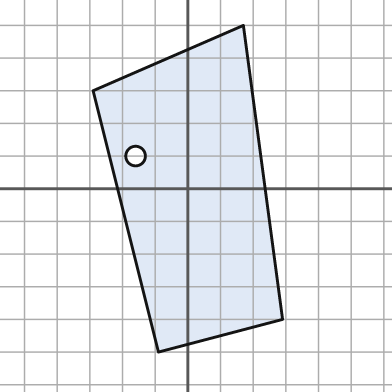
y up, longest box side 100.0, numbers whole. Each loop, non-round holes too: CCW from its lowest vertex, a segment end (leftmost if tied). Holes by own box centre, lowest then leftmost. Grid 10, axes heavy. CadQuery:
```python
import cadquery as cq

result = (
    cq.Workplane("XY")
    .moveTo(-9.0, -50.0)
    .lineTo(29.0, -40.0)
    .lineTo(17.0, 50.0)
    .lineTo(-29.0, 30.0)
    .close()
    .moveTo(-16.0, 10.0)
    .circle(3.0)
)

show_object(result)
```